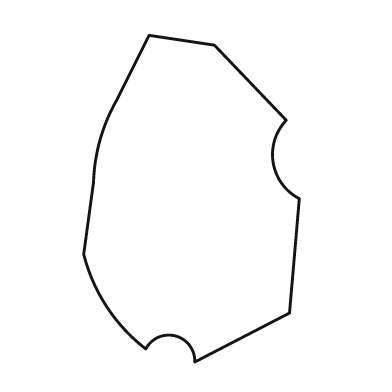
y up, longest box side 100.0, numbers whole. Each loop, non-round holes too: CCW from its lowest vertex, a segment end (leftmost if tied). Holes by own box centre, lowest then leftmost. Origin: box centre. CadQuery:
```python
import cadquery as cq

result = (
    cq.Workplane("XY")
    .moveTo(1.0, -50.0)
    .lineTo(30.0, -35.0)
    .lineTo(33.0, 0.0)
    .threePointArc((25.0, 11.0), (29.0, 24.0))
    .lineTo(7.0, 47.0)
    .lineTo(-13.0, 50.0)
    .lineTo(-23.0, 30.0)
    .threePointArc((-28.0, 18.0), (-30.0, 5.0))
    .lineTo(-33.0, -17.0)
    .threePointArc((-26.0, -33.0), (-14.0, -46.0))
    .threePointArc((-5.0, -42.0), (1.0, -50.0))
    .close()
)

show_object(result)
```